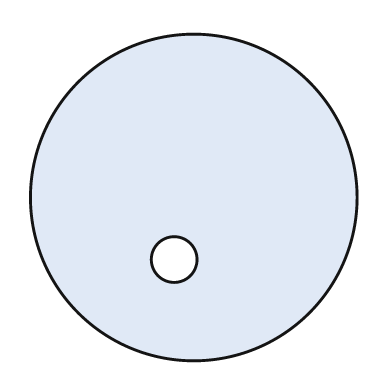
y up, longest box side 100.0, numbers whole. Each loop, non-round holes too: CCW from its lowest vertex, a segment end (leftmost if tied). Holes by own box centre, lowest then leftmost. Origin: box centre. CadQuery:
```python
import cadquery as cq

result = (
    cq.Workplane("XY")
    .moveTo(0.0, 0.0)
    .circle(50.0)
    .moveTo(-6.0, -19.0)
    .circle(7.0)
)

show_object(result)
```